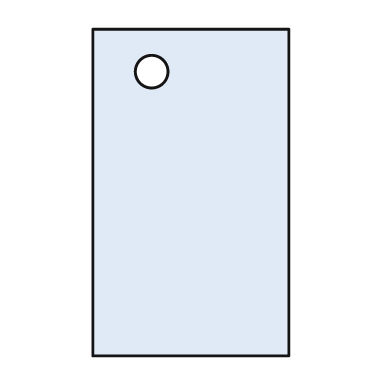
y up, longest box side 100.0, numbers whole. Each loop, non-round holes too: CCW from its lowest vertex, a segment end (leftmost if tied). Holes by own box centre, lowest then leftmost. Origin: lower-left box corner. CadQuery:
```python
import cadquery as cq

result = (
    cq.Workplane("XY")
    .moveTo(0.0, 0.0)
    .lineTo(60.0, 0.0)
    .lineTo(60.0, 100.0)
    .lineTo(0.0, 100.0)
    .close()
    .moveTo(18.0, 87.0)
    .circle(5.0)
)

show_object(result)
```